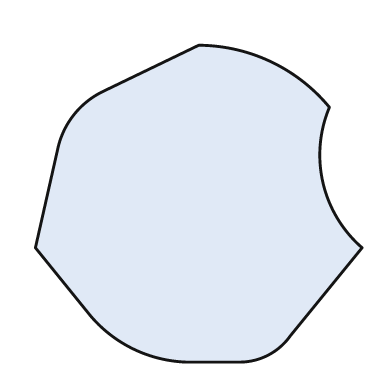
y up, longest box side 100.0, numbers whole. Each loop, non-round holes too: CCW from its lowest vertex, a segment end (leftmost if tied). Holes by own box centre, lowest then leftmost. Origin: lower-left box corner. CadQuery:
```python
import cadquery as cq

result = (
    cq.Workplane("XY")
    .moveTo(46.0, 0.0)
    .lineTo(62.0, 0.0)
    .threePointArc((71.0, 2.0), (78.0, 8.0))
    .lineTo(100.0, 35.0)
    .threePointArc((88.0, 55.0), (90.0, 78.0))
    .threePointArc((72.0, 92.0), (50.0, 97.0))
    .lineTo(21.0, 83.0)
    .threePointArc((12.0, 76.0), (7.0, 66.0))
    .lineTo(0.0, 35.0)
    .lineTo(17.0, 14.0)
    .threePointArc((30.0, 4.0), (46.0, 0.0))
    .close()
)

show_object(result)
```